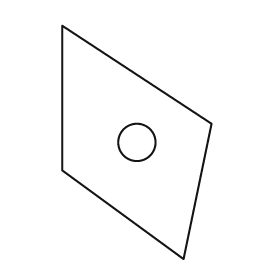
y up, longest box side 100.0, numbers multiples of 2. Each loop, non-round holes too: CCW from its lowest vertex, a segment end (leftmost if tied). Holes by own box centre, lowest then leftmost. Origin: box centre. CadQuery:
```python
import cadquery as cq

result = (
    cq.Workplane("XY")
    .moveTo(20.0, -50.0)
    .lineTo(32.0, 8.0)
    .lineTo(-32.0, 50.0)
    .lineTo(-32.0, -12.0)
    .close()
    .moveTo(0.0, 0.0)
    .circle(8.0)
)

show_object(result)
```